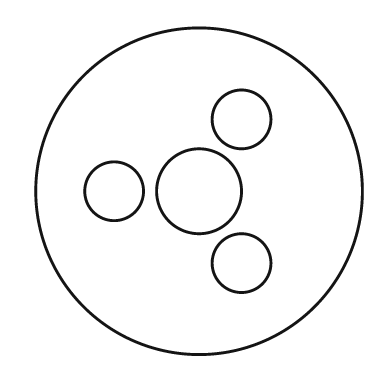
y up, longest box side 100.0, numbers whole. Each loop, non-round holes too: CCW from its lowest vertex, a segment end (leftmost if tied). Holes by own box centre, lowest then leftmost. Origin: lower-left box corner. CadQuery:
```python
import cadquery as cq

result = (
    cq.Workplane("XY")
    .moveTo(50.0, 50.0)
    .circle(50.0)
    .moveTo(63.0, 28.0)
    .circle(9.0)
    .moveTo(24.0, 50.0)
    .circle(9.0)
    .moveTo(50.0, 50.0)
    .circle(13.0)
    .moveTo(63.0, 72.0)
    .circle(9.0)
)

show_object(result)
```